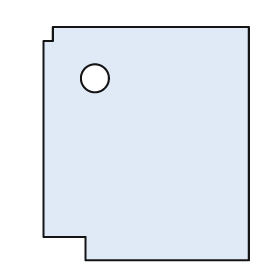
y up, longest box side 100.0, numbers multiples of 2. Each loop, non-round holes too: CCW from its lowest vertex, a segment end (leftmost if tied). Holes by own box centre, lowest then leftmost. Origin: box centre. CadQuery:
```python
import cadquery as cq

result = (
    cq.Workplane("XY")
    .moveTo(-26.0, -50.0)
    .lineTo(44.0, -50.0)
    .lineTo(44.0, 50.0)
    .lineTo(-40.0, 50.0)
    .lineTo(-40.0, 44.0)
    .lineTo(-44.0, 44.0)
    .lineTo(-44.0, -40.0)
    .lineTo(-26.0, -40.0)
    .close()
    .moveTo(-22.0, 28.0)
    .circle(6.0)
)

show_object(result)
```